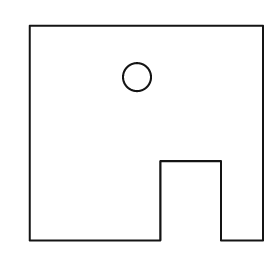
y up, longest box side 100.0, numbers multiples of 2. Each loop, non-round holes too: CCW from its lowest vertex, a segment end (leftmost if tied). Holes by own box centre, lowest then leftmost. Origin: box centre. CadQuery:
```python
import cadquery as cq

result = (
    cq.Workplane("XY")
    .moveTo(-50.0, -46.0)
    .lineTo(6.0, -46.0)
    .lineTo(6.0, -12.0)
    .lineTo(32.0, -12.0)
    .lineTo(32.0, -46.0)
    .lineTo(50.0, -46.0)
    .lineTo(50.0, 46.0)
    .lineTo(-50.0, 46.0)
    .close()
    .moveTo(-4.0, 24.0)
    .circle(6.0)
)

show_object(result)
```